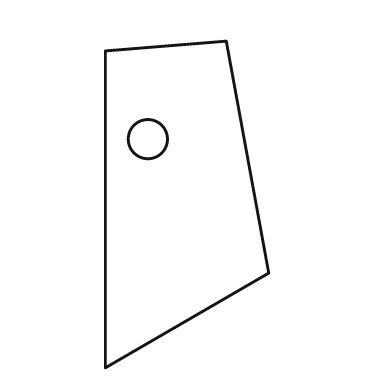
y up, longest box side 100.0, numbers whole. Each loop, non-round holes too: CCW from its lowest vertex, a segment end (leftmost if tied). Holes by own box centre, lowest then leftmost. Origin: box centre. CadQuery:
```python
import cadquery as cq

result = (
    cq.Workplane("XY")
    .moveTo(-25.0, -50.0)
    .lineTo(25.0, -21.0)
    .lineTo(12.0, 50.0)
    .lineTo(-25.0, 47.0)
    .close()
    .moveTo(-12.0, 20.0)
    .circle(6.0)
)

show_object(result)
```